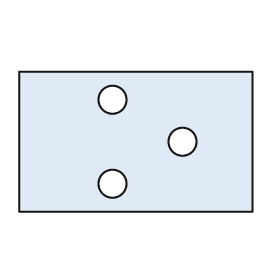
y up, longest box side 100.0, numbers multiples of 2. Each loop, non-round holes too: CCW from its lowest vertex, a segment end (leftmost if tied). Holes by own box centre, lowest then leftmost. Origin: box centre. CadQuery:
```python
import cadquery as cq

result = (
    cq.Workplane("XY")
    .moveTo(-50.0, -30.0)
    .lineTo(50.0, -30.0)
    .lineTo(50.0, 30.0)
    .lineTo(-50.0, 30.0)
    .close()
    .moveTo(-10.0, -18.0)
    .circle(6.0)
    .moveTo(20.0, 0.0)
    .circle(6.0)
    .moveTo(-10.0, 18.0)
    .circle(6.0)
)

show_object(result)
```